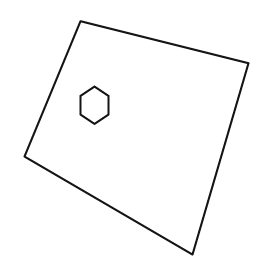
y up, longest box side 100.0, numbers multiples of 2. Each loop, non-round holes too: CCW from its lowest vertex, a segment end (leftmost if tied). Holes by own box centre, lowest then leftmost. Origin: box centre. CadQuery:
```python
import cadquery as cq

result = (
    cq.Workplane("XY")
    .moveTo(24.0, -50.0)
    .lineTo(48.0, 32.0)
    .lineTo(-24.0, 50.0)
    .lineTo(-48.0, -8.0)
    .close()
    .moveTo(-18.0, 6.0)
    .lineTo(-12.0, 10.0)
    .lineTo(-12.0, 18.0)
    .lineTo(-18.0, 22.0)
    .lineTo(-24.0, 18.0)
    .lineTo(-24.0, 10.0)
    .close()
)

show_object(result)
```